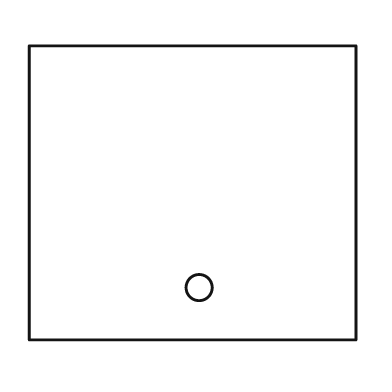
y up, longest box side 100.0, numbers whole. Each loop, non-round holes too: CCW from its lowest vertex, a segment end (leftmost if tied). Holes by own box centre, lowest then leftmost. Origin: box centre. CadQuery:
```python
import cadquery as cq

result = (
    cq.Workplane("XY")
    .moveTo(-50.0, -45.0)
    .lineTo(50.0, -45.0)
    .lineTo(50.0, 45.0)
    .lineTo(-50.0, 45.0)
    .close()
    .moveTo(2.0, -29.0)
    .circle(4.0)
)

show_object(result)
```